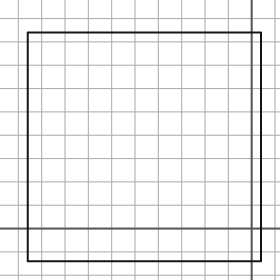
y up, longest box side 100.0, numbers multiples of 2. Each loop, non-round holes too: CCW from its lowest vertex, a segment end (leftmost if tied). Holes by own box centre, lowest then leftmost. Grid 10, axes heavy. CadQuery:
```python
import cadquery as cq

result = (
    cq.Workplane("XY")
    .moveTo(-96.0, -14.0)
    .lineTo(4.0, -14.0)
    .lineTo(4.0, 84.0)
    .lineTo(-96.0, 84.0)
    .close()
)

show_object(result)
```